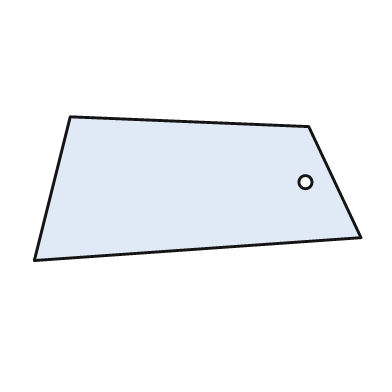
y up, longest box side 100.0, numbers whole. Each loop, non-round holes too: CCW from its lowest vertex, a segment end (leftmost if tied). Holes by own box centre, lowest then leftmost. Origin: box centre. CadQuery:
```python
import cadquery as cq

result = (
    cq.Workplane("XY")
    .moveTo(-50.0, -22.0)
    .lineTo(50.0, -15.0)
    .lineTo(34.0, 19.0)
    .lineTo(-39.0, 22.0)
    .close()
    .moveTo(33.0, 2.0)
    .circle(2.0)
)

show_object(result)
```